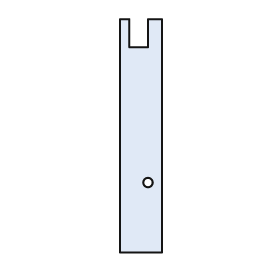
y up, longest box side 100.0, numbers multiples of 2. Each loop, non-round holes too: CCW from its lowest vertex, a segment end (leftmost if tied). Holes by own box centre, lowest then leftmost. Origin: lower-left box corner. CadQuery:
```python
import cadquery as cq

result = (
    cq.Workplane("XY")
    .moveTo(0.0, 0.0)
    .lineTo(18.0, 0.0)
    .lineTo(18.0, 100.0)
    .lineTo(12.0, 100.0)
    .lineTo(12.0, 88.0)
    .lineTo(4.0, 88.0)
    .lineTo(4.0, 100.0)
    .lineTo(0.0, 100.0)
    .close()
    .moveTo(12.0, 30.0)
    .circle(2.0)
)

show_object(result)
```